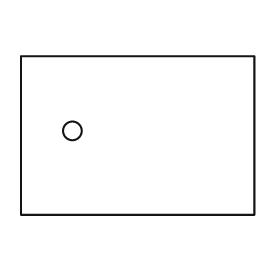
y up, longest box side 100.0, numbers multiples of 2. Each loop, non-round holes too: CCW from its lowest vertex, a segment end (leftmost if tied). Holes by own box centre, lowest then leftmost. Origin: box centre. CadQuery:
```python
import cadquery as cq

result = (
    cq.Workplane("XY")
    .moveTo(-50.0, -34.0)
    .lineTo(50.0, -34.0)
    .lineTo(50.0, 34.0)
    .lineTo(-50.0, 34.0)
    .close()
    .moveTo(-28.0, 2.0)
    .circle(4.0)
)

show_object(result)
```